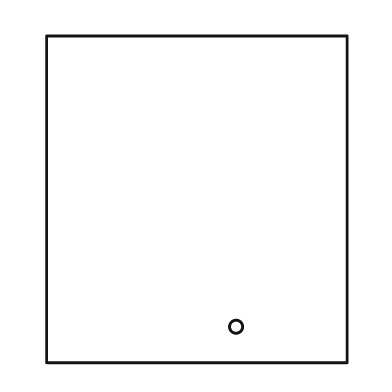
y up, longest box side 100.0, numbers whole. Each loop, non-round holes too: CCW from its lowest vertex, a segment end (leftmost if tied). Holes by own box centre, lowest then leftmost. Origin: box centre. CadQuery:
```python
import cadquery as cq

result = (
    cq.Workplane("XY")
    .moveTo(-46.0, -50.0)
    .lineTo(46.0, -50.0)
    .lineTo(46.0, 50.0)
    .lineTo(-46.0, 50.0)
    .close()
    .moveTo(12.0, -39.0)
    .circle(2.0)
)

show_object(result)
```